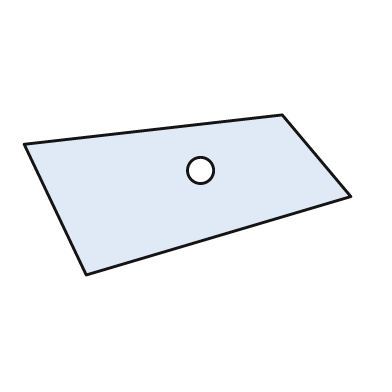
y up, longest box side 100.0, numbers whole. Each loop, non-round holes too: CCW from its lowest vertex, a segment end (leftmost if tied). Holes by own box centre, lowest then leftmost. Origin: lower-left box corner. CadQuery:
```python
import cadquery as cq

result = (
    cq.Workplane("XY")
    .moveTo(19.0, 0.0)
    .lineTo(100.0, 24.0)
    .lineTo(79.0, 49.0)
    .lineTo(0.0, 40.0)
    .close()
    .moveTo(54.0, 32.0)
    .circle(4.0)
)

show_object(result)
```